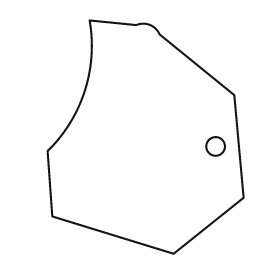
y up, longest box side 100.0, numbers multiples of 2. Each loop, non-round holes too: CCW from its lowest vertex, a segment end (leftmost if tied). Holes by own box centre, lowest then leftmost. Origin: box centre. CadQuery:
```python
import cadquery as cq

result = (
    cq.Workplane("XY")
    .moveTo(12.0, -50.0)
    .lineTo(42.0, -26.0)
    .lineTo(38.0, 18.0)
    .lineTo(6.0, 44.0)
    .threePointArc((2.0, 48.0), (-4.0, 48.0))
    .lineTo(-24.0, 50.0)
    .threePointArc((-26.0, 20.0), (-42.0, -6.0))
    .lineTo(-40.0, -34.0)
    .close()
    .moveTo(30.0, -4.0)
    .circle(4.0)
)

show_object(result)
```